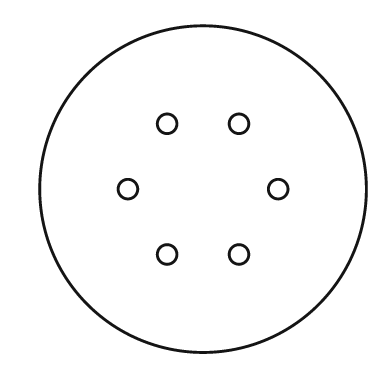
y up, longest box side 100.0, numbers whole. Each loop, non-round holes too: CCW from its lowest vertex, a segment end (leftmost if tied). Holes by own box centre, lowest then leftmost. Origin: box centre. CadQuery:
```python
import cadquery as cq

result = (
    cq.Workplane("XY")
    .moveTo(0.0, 0.0)
    .circle(50.0)
    .moveTo(-11.0, -20.0)
    .circle(3.0)
    .moveTo(11.0, -20.0)
    .circle(3.0)
    .moveTo(-23.0, 0.0)
    .circle(3.0)
    .moveTo(23.0, 0.0)
    .circle(3.0)
    .moveTo(-11.0, 20.0)
    .circle(3.0)
    .moveTo(11.0, 20.0)
    .circle(3.0)
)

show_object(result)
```